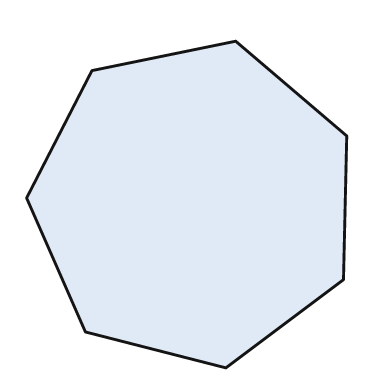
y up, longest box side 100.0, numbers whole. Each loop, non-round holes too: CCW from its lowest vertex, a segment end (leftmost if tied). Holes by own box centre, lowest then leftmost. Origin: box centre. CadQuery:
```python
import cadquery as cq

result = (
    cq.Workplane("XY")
    .moveTo(12.0, -50.0)
    .lineTo(48.0, -23.0)
    .lineTo(49.0, 21.0)
    .lineTo(15.0, 50.0)
    .lineTo(-29.0, 41.0)
    .lineTo(-49.0, 2.0)
    .lineTo(-31.0, -39.0)
    .close()
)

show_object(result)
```